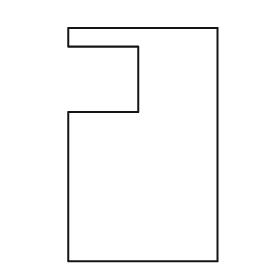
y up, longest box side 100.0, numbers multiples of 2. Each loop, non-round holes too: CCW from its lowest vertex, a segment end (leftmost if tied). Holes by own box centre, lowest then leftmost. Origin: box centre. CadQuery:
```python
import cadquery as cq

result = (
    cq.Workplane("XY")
    .moveTo(-32.0, -50.0)
    .lineTo(32.0, -50.0)
    .lineTo(32.0, 50.0)
    .lineTo(-32.0, 50.0)
    .lineTo(-32.0, 42.0)
    .lineTo(-2.0, 42.0)
    .lineTo(-2.0, 14.0)
    .lineTo(-32.0, 14.0)
    .close()
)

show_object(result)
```